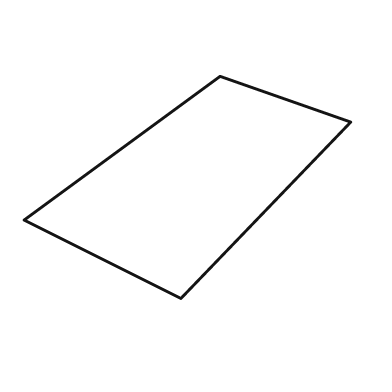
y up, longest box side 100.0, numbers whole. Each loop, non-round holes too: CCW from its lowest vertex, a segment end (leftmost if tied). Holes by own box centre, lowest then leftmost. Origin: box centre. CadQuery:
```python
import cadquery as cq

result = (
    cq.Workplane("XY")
    .moveTo(-2.0, -34.0)
    .lineTo(50.0, 20.0)
    .lineTo(10.0, 34.0)
    .lineTo(-50.0, -10.0)
    .close()
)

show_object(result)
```